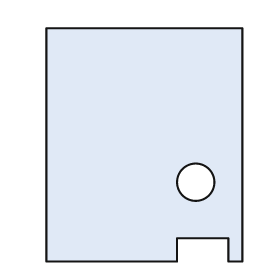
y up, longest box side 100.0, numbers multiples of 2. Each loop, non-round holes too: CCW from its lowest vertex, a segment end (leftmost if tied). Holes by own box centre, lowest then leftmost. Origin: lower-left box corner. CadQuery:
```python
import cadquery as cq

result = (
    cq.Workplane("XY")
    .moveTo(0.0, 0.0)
    .lineTo(56.0, 0.0)
    .lineTo(56.0, 10.0)
    .lineTo(78.0, 10.0)
    .lineTo(78.0, 0.0)
    .lineTo(84.0, 0.0)
    .lineTo(84.0, 100.0)
    .lineTo(0.0, 100.0)
    .close()
    .moveTo(64.0, 34.0)
    .circle(8.0)
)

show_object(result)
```